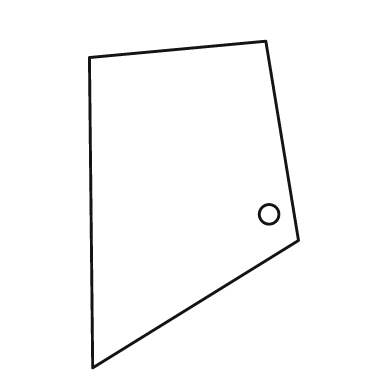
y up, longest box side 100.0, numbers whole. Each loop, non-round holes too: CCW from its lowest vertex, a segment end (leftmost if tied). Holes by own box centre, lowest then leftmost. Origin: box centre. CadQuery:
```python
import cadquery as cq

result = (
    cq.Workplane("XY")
    .moveTo(-31.0, -50.0)
    .lineTo(32.0, -11.0)
    .lineTo(22.0, 50.0)
    .lineTo(-32.0, 45.0)
    .close()
    .moveTo(23.0, -3.0)
    .circle(3.0)
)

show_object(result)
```